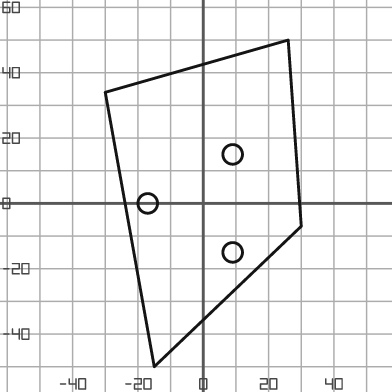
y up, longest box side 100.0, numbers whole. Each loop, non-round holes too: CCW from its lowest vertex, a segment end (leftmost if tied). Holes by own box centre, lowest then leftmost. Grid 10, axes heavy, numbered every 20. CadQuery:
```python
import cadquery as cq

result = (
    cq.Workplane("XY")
    .moveTo(-15.0, -50.0)
    .lineTo(30.0, -7.0)
    .lineTo(26.0, 50.0)
    .lineTo(-30.0, 34.0)
    .close()
    .moveTo(9.0, -15.0)
    .circle(3.0)
    .moveTo(-17.0, 0.0)
    .circle(3.0)
    .moveTo(9.0, 15.0)
    .circle(3.0)
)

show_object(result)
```